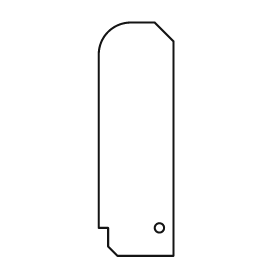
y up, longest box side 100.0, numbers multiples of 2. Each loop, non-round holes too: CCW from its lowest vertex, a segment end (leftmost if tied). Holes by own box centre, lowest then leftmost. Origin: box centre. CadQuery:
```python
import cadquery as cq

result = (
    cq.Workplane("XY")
    .moveTo(-8.0, -50.0)
    .lineTo(16.0, -50.0)
    .lineTo(16.0, 42.0)
    .lineTo(8.0, 50.0)
    .lineTo(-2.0, 50.0)
    .threePointArc((-12.0, 46.0), (-16.0, 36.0))
    .lineTo(-16.0, -38.0)
    .lineTo(-12.0, -38.0)
    .lineTo(-12.0, -46.0)
    .close()
    .moveTo(10.0, -38.0)
    .circle(2.0)
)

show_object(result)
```